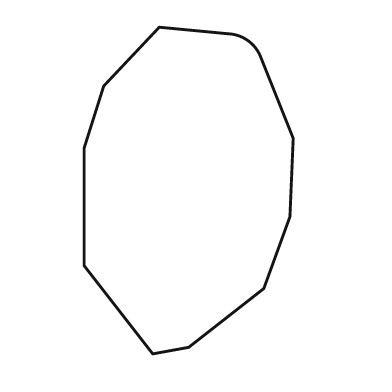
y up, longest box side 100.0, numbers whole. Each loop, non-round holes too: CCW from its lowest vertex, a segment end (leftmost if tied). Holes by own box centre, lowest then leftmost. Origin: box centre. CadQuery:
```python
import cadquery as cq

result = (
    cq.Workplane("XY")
    .moveTo(-11.0, -50.0)
    .lineTo(0.0, -48.0)
    .lineTo(23.0, -30.0)
    .lineTo(31.0, -8.0)
    .lineTo(32.0, 16.0)
    .lineTo(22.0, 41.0)
    .threePointArc((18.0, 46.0), (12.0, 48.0))
    .lineTo(-9.0, 50.0)
    .lineTo(-26.0, 32.0)
    .lineTo(-32.0, 13.0)
    .lineTo(-32.0, -23.0)
    .close()
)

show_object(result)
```